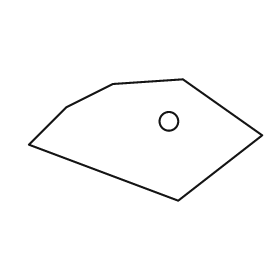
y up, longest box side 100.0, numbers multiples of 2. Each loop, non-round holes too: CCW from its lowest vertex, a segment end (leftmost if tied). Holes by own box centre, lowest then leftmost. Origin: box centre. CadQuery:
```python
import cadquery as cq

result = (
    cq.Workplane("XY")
    .moveTo(14.0, -26.0)
    .lineTo(50.0, 2.0)
    .lineTo(16.0, 26.0)
    .lineTo(-14.0, 24.0)
    .lineTo(-34.0, 14.0)
    .lineTo(-50.0, -2.0)
    .close()
    .moveTo(10.0, 8.0)
    .circle(4.0)
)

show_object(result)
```